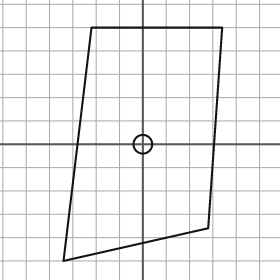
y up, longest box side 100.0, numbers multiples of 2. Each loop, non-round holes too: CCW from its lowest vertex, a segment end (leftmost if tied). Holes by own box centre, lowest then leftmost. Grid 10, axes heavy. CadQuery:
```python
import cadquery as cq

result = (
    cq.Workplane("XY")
    .moveTo(-34.0, -50.0)
    .lineTo(28.0, -36.0)
    .lineTo(34.0, 50.0)
    .lineTo(-22.0, 50.0)
    .close()
    .moveTo(0.0, 0.0)
    .circle(4.0)
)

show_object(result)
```